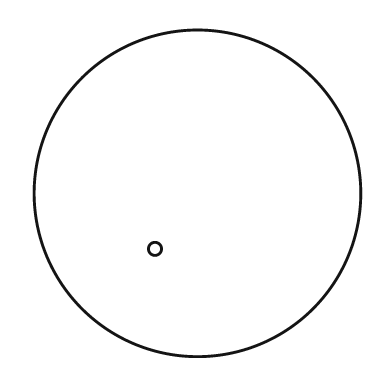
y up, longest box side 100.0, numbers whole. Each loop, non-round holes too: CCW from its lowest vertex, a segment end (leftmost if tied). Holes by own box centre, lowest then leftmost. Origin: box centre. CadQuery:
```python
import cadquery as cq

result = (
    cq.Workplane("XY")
    .moveTo(0.0, 0.0)
    .circle(50.0)
    .moveTo(-13.0, -17.0)
    .circle(2.0)
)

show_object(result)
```